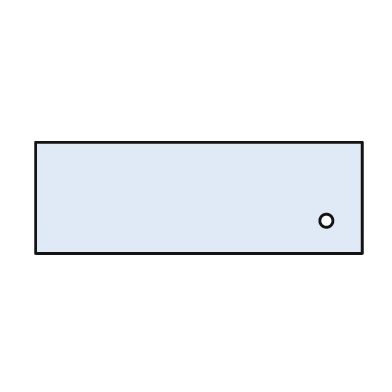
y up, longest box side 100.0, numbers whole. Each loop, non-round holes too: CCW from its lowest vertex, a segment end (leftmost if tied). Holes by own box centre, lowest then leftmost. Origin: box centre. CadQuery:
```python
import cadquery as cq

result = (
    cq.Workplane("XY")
    .moveTo(-50.0, -17.0)
    .lineTo(50.0, -17.0)
    .lineTo(50.0, 17.0)
    .lineTo(-50.0, 17.0)
    .close()
    .moveTo(39.0, -7.0)
    .circle(2.0)
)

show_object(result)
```